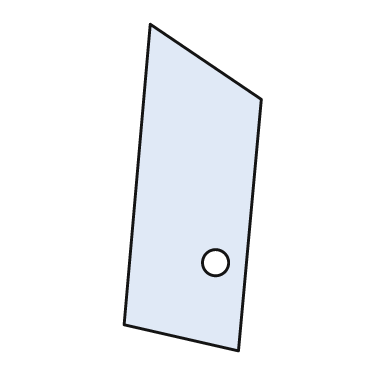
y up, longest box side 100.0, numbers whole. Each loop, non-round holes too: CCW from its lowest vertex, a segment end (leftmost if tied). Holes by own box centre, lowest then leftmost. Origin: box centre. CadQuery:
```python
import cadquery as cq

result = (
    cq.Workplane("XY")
    .moveTo(14.0, -50.0)
    .lineTo(21.0, 27.0)
    .lineTo(-13.0, 50.0)
    .lineTo(-21.0, -42.0)
    .close()
    .moveTo(7.0, -23.0)
    .circle(4.0)
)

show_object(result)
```